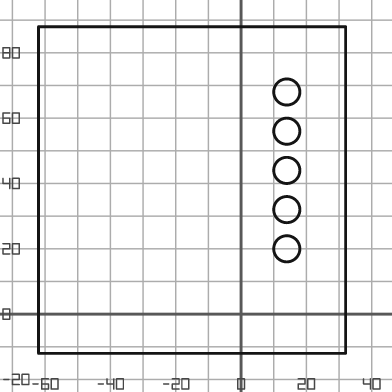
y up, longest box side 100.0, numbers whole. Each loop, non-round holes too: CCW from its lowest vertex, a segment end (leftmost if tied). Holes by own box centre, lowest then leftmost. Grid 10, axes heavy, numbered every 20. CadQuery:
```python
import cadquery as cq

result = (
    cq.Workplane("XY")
    .moveTo(-62.0, -12.0)
    .lineTo(32.0, -12.0)
    .lineTo(32.0, 88.0)
    .lineTo(-62.0, 88.0)
    .close()
    .moveTo(14.0, 20.0)
    .circle(4.0)
    .moveTo(14.0, 32.0)
    .circle(4.0)
    .moveTo(14.0, 44.0)
    .circle(4.0)
    .moveTo(14.0, 56.0)
    .circle(4.0)
    .moveTo(14.0, 68.0)
    .circle(4.0)
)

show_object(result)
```